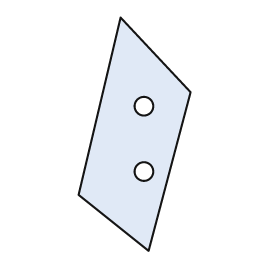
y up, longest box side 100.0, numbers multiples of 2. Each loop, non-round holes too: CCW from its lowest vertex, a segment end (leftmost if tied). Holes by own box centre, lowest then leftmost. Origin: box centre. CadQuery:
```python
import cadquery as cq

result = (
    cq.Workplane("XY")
    .moveTo(6.0, -50.0)
    .lineTo(24.0, 18.0)
    .lineTo(-6.0, 50.0)
    .lineTo(-24.0, -26.0)
    .close()
    .moveTo(4.0, -16.0)
    .circle(4.0)
    .moveTo(4.0, 12.0)
    .circle(4.0)
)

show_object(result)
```